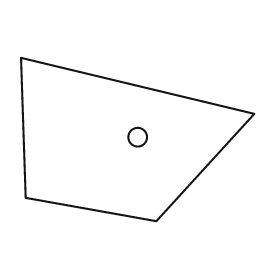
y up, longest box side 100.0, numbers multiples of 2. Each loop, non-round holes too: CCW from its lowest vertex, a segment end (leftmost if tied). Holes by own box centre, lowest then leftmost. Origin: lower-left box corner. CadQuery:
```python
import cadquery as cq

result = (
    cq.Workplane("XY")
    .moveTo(58.0, 0.0)
    .lineTo(100.0, 46.0)
    .lineTo(0.0, 70.0)
    .lineTo(2.0, 10.0)
    .close()
    .moveTo(50.0, 36.0)
    .circle(4.0)
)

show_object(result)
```